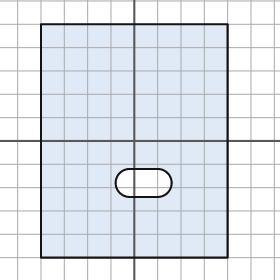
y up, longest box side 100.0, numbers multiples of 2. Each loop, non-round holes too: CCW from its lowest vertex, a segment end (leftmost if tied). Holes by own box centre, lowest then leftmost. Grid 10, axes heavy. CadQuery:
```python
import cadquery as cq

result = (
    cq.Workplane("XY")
    .moveTo(-40.0, -50.0)
    .lineTo(40.0, -50.0)
    .lineTo(40.0, 50.0)
    .lineTo(-40.0, 50.0)
    .close()
    .moveTo(-2.0, -24.0)
    .lineTo(10.0, -24.0)
    .threePointArc((16.0, -18.0), (10.0, -12.0))
    .lineTo(-2.0, -12.0)
    .threePointArc((-8.0, -18.0), (-2.0, -24.0))
    .close()
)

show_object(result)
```